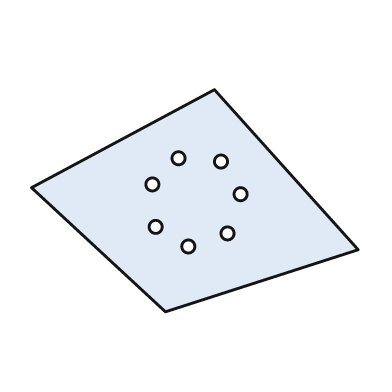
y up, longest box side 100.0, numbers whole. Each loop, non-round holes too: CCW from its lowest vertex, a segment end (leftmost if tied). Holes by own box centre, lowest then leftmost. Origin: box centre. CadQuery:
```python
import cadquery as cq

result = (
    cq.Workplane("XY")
    .moveTo(-9.0, -34.0)
    .lineTo(50.0, -15.0)
    .lineTo(6.0, 34.0)
    .lineTo(-50.0, 4.0)
    .close()
    .moveTo(-2.0, -14.0)
    .circle(2.0)
    .moveTo(10.0, -10.0)
    .circle(2.0)
    .moveTo(-12.0, -8.0)
    .circle(2.0)
    .moveTo(14.0, 2.0)
    .circle(2.0)
    .moveTo(-13.0, 5.0)
    .circle(2.0)
    .moveTo(8.0, 12.0)
    .circle(2.0)
    .moveTo(-5.0, 13.0)
    .circle(2.0)
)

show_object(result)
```